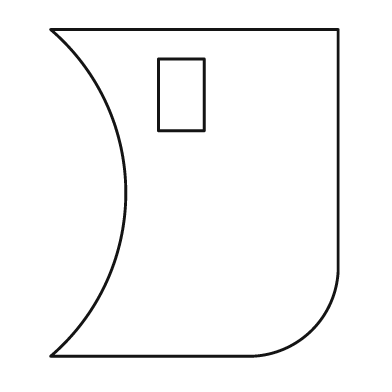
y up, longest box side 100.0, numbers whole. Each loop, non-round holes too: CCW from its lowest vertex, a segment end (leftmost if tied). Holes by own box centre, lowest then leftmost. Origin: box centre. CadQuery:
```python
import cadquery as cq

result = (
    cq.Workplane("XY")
    .moveTo(-44.0, -50.0)
    .lineTo(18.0, -50.0)
    .threePointArc((36.0, -42.0), (44.0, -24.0))
    .lineTo(44.0, 50.0)
    .lineTo(-44.0, 50.0)
    .threePointArc((-21.0, 0.0), (-44.0, -50.0))
    .close()
    .moveTo(-11.0, 19.0)
    .lineTo(3.0, 19.0)
    .lineTo(3.0, 41.0)
    .lineTo(-11.0, 41.0)
    .close()
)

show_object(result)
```